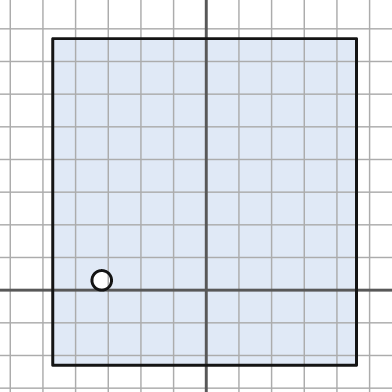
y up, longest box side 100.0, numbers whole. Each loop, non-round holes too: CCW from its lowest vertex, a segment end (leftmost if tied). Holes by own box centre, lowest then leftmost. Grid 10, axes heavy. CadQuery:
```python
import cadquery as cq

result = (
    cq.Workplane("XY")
    .moveTo(-47.0, -23.0)
    .lineTo(46.0, -23.0)
    .lineTo(46.0, 77.0)
    .lineTo(-47.0, 77.0)
    .close()
    .moveTo(-32.0, 3.0)
    .circle(3.0)
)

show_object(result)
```